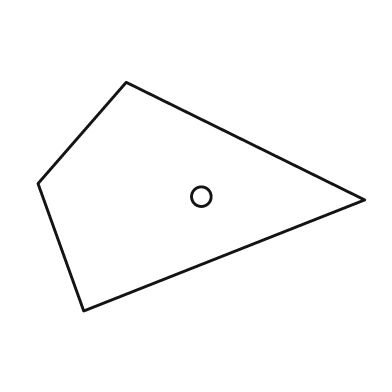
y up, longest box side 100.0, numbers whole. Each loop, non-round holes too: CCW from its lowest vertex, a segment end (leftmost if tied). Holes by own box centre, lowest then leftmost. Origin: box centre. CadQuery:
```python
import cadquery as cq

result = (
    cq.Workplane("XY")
    .moveTo(-36.0, -35.0)
    .lineTo(50.0, -1.0)
    .lineTo(-23.0, 35.0)
    .lineTo(-50.0, 4.0)
    .close()
    .moveTo(0.0, 0.0)
    .circle(3.0)
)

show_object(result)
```